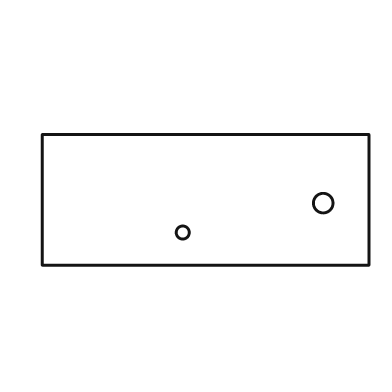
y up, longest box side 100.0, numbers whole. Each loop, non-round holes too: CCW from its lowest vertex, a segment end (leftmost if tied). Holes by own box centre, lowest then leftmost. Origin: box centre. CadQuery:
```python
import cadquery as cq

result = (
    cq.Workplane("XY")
    .moveTo(-50.0, -20.0)
    .lineTo(50.0, -20.0)
    .lineTo(50.0, 20.0)
    .lineTo(-50.0, 20.0)
    .close()
    .moveTo(-7.0, -10.0)
    .circle(2.0)
    .moveTo(36.0, -1.0)
    .circle(3.0)
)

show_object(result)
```